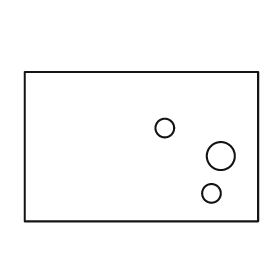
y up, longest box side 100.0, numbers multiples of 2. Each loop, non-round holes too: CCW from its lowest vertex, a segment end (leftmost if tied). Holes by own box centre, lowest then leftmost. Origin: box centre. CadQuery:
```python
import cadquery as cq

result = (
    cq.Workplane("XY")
    .moveTo(-50.0, -32.0)
    .lineTo(50.0, -32.0)
    .lineTo(50.0, 32.0)
    .lineTo(-50.0, 32.0)
    .close()
    .moveTo(30.0, -20.0)
    .circle(4.0)
    .moveTo(34.0, -4.0)
    .circle(6.0)
    .moveTo(10.0, 8.0)
    .circle(4.0)
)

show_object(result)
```